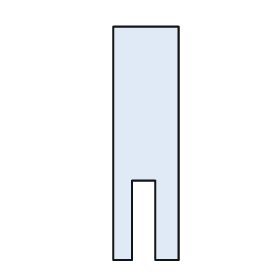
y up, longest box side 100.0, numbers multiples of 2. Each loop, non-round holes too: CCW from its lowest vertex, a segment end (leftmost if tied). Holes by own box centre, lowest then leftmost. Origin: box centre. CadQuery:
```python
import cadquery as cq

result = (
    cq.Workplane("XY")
    .moveTo(-14.0, -50.0)
    .lineTo(-6.0, -50.0)
    .lineTo(-6.0, -16.0)
    .lineTo(4.0, -16.0)
    .lineTo(4.0, -50.0)
    .lineTo(14.0, -50.0)
    .lineTo(14.0, 50.0)
    .lineTo(-14.0, 50.0)
    .close()
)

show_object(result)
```